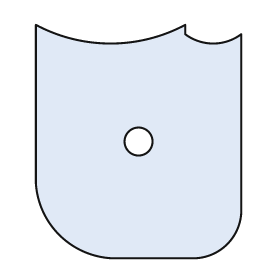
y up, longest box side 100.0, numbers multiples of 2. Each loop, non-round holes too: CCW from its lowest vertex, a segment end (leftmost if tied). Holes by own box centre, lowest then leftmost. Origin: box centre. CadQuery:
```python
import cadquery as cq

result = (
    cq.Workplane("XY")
    .moveTo(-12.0, -50.0)
    .lineTo(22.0, -50.0)
    .threePointArc((38.0, -44.0), (44.0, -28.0))
    .lineTo(44.0, 46.0)
    .threePointArc((32.0, 42.0), (20.0, 46.0))
    .lineTo(20.0, 50.0)
    .threePointArc((-12.0, 42.0), (-44.0, 50.0))
    .lineTo(-44.0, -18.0)
    .threePointArc((-34.0, -40.0), (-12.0, -50.0))
    .close()
    .moveTo(0.0, 0.0)
    .circle(6.0)
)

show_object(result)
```